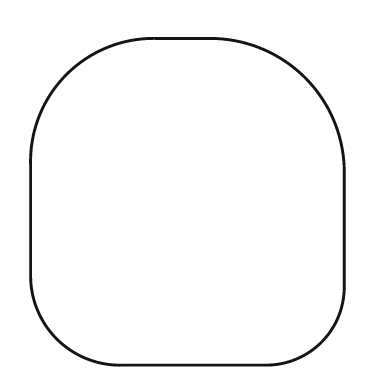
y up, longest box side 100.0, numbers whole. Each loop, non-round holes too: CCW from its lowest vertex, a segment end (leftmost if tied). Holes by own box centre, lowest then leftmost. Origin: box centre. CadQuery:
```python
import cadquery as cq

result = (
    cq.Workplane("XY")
    .moveTo(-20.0, -50.0)
    .lineTo(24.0, -50.0)
    .threePointArc((41.0, -43.0), (48.0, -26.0))
    .lineTo(48.0, 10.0)
    .threePointArc((36.0, 38.0), (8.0, 50.0))
    .lineTo(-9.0, 50.0)
    .threePointArc((-37.0, 39.0), (-48.0, 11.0))
    .lineTo(-48.0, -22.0)
    .threePointArc((-40.0, -42.0), (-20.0, -50.0))
    .close()
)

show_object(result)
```